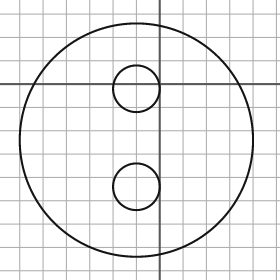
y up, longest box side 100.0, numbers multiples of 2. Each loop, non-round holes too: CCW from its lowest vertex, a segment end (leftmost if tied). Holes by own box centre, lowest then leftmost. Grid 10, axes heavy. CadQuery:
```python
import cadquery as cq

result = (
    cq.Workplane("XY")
    .moveTo(-10.0, -24.0)
    .circle(50.0)
    .moveTo(-10.0, -44.0)
    .circle(10.0)
    .moveTo(-10.0, -2.0)
    .circle(10.0)
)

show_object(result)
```